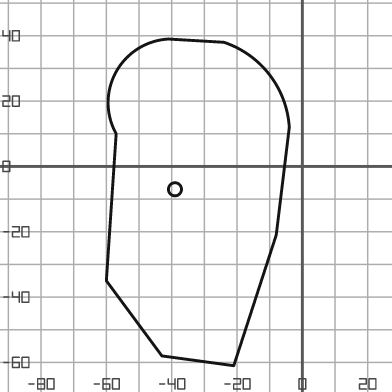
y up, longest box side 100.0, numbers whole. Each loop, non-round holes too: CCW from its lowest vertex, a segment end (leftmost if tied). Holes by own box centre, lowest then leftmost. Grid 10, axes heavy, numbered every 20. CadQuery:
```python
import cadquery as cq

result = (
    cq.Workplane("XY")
    .moveTo(-21.0, -61.0)
    .lineTo(-8.0, -21.0)
    .lineTo(-4.0, 12.0)
    .threePointArc((-10.0, 28.0), (-24.0, 38.0))
    .lineTo(-41.0, 39.0)
    .threePointArc((-57.0, 29.0), (-57.0, 10.0))
    .lineTo(-60.0, -35.0)
    .lineTo(-43.0, -58.0)
    .close()
    .moveTo(-39.0, -7.0)
    .circle(2.0)
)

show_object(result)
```